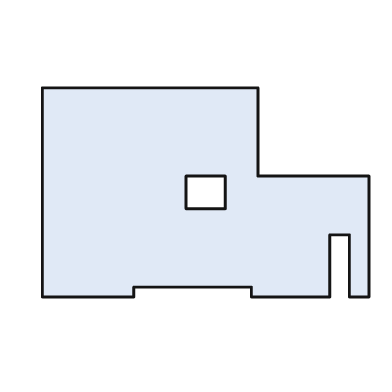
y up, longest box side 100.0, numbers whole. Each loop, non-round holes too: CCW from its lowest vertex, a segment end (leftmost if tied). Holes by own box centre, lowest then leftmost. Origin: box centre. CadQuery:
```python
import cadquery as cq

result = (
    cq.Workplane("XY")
    .moveTo(-50.0, -32.0)
    .lineTo(-22.0, -32.0)
    .lineTo(-22.0, -29.0)
    .lineTo(14.0, -29.0)
    .lineTo(14.0, -32.0)
    .lineTo(38.0, -32.0)
    .lineTo(38.0, -13.0)
    .lineTo(44.0, -13.0)
    .lineTo(44.0, -32.0)
    .lineTo(50.0, -32.0)
    .lineTo(50.0, 5.0)
    .lineTo(16.0, 5.0)
    .lineTo(16.0, 32.0)
    .lineTo(-50.0, 32.0)
    .close()
    .moveTo(-6.0, -5.0)
    .lineTo(6.0, -5.0)
    .lineTo(6.0, 5.0)
    .lineTo(-6.0, 5.0)
    .close()
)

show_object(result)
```